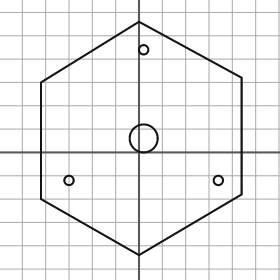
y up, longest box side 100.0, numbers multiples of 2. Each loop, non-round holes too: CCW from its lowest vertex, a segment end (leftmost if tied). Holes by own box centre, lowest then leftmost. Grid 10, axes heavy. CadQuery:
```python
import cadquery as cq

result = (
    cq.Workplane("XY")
    .moveTo(0.0, -44.0)
    .lineTo(44.0, -18.0)
    .lineTo(44.0, 32.0)
    .lineTo(0.0, 56.0)
    .lineTo(-42.0, 30.0)
    .lineTo(-42.0, -20.0)
    .close()
    .moveTo(-30.0, -12.0)
    .circle(2.0)
    .moveTo(34.0, -12.0)
    .circle(2.0)
    .moveTo(2.0, 6.0)
    .circle(6.0)
    .moveTo(2.0, 44.0)
    .circle(2.0)
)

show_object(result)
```